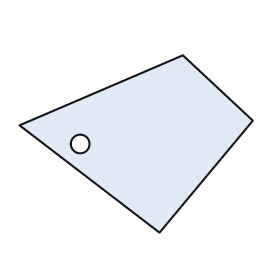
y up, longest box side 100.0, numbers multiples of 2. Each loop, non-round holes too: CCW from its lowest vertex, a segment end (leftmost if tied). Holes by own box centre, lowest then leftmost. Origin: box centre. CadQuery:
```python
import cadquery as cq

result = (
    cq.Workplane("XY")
    .moveTo(10.0, -38.0)
    .lineTo(50.0, 10.0)
    .lineTo(20.0, 38.0)
    .lineTo(-50.0, 8.0)
    .close()
    .moveTo(-24.0, 0.0)
    .circle(4.0)
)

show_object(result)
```